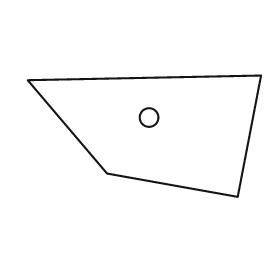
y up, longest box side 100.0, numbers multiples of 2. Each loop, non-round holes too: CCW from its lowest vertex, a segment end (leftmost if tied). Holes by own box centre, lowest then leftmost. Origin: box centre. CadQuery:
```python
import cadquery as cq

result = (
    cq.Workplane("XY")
    .moveTo(40.0, -26.0)
    .lineTo(50.0, 26.0)
    .lineTo(-50.0, 24.0)
    .lineTo(-16.0, -16.0)
    .close()
    .moveTo(2.0, 8.0)
    .circle(4.0)
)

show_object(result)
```